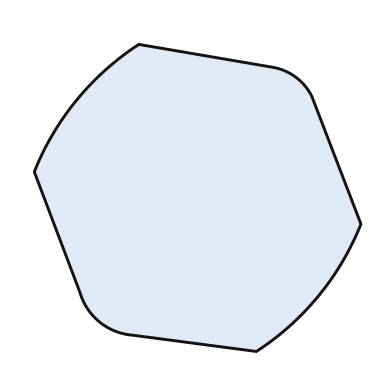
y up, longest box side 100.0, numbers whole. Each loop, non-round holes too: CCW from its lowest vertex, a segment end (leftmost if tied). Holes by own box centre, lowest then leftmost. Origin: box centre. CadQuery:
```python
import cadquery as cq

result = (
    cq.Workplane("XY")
    .moveTo(18.0, -47.0)
    .threePointArc((37.0, -30.0), (50.0, -8.0))
    .lineTo(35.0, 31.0)
    .threePointArc((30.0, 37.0), (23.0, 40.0))
    .lineTo(-18.0, 47.0)
    .threePointArc((-37.0, 30.0), (-50.0, 8.0))
    .lineTo(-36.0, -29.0)
    .threePointArc((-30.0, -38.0), (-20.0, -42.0))
    .close()
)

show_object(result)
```